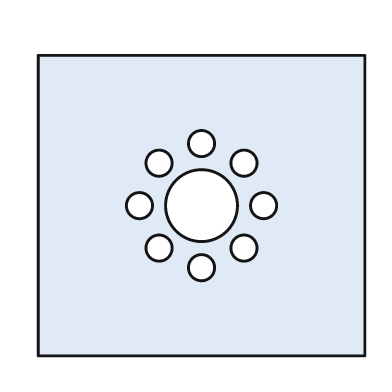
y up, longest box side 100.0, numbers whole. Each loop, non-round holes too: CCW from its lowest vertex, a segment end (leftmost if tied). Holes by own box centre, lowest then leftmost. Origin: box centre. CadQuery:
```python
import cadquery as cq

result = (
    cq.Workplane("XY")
    .moveTo(-50.0, -46.0)
    .lineTo(50.0, -46.0)
    .lineTo(50.0, 46.0)
    .lineTo(-50.0, 46.0)
    .close()
    .moveTo(0.0, -19.0)
    .circle(4.0)
    .moveTo(-13.0, -13.0)
    .circle(4.0)
    .moveTo(13.0, -13.0)
    .circle(4.0)
    .moveTo(-19.0, 0.0)
    .circle(4.0)
    .moveTo(0.0, 0.0)
    .circle(11.0)
    .moveTo(19.0, 0.0)
    .circle(4.0)
    .moveTo(-13.0, 13.0)
    .circle(4.0)
    .moveTo(13.0, 13.0)
    .circle(4.0)
    .moveTo(0.0, 19.0)
    .circle(4.0)
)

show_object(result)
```